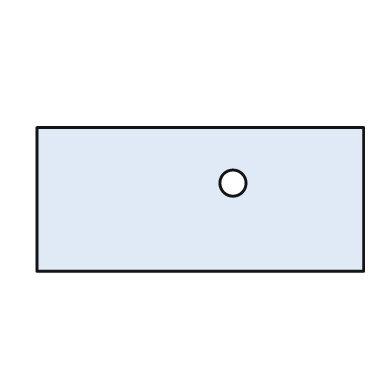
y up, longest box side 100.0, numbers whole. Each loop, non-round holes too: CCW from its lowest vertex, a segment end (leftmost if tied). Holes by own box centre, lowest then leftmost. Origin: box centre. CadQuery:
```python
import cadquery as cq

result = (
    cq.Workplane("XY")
    .moveTo(-50.0, -22.0)
    .lineTo(50.0, -22.0)
    .lineTo(50.0, 22.0)
    .lineTo(-50.0, 22.0)
    .close()
    .moveTo(10.0, 5.0)
    .circle(4.0)
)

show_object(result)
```